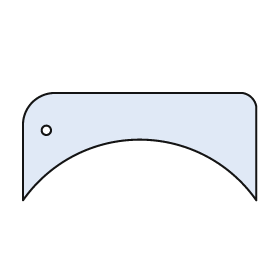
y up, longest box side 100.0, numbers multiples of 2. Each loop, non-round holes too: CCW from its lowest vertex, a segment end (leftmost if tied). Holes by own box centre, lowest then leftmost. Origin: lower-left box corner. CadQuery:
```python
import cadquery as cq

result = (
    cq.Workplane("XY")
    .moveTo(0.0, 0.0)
    .threePointArc((50.0, 26.0), (100.0, 0.0))
    .lineTo(100.0, 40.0)
    .threePointArc((98.0, 44.0), (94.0, 46.0))
    .lineTo(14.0, 46.0)
    .threePointArc((4.0, 42.0), (0.0, 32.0))
    .close()
    .moveTo(10.0, 30.0)
    .circle(2.0)
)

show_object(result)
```